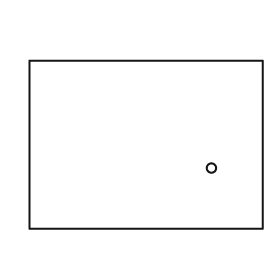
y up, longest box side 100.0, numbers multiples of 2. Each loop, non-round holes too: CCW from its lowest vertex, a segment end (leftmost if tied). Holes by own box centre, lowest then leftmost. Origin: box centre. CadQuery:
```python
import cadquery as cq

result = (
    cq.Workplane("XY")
    .moveTo(-50.0, -36.0)
    .lineTo(50.0, -36.0)
    .lineTo(50.0, 36.0)
    .lineTo(-50.0, 36.0)
    .close()
    .moveTo(28.0, -10.0)
    .circle(2.0)
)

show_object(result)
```